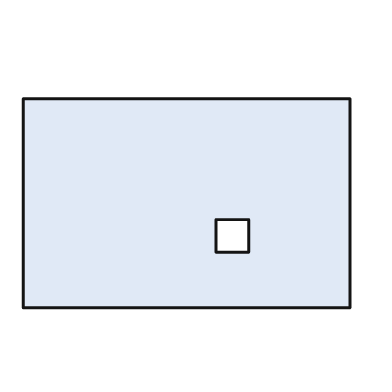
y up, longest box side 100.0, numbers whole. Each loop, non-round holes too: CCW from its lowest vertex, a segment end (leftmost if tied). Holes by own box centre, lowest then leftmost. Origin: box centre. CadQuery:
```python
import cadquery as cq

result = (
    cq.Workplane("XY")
    .moveTo(-50.0, -32.0)
    .lineTo(50.0, -32.0)
    .lineTo(50.0, 32.0)
    .lineTo(-50.0, 32.0)
    .close()
    .moveTo(9.0, -15.0)
    .lineTo(19.0, -15.0)
    .lineTo(19.0, -5.0)
    .lineTo(9.0, -5.0)
    .close()
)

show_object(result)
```